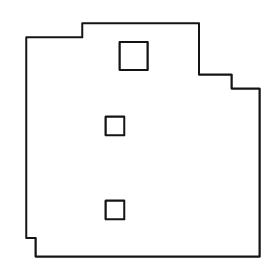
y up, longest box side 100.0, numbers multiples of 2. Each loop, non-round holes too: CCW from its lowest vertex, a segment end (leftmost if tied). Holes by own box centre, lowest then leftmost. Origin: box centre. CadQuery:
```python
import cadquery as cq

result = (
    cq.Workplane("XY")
    .moveTo(-46.0, -50.0)
    .lineTo(50.0, -50.0)
    .lineTo(50.0, 22.0)
    .lineTo(38.0, 22.0)
    .lineTo(38.0, 28.0)
    .lineTo(24.0, 28.0)
    .lineTo(24.0, 50.0)
    .lineTo(-26.0, 50.0)
    .lineTo(-26.0, 44.0)
    .lineTo(-50.0, 44.0)
    .lineTo(-50.0, -42.0)
    .lineTo(-46.0, -42.0)
    .close()
    .moveTo(-16.0, -34.0)
    .lineTo(-8.0, -34.0)
    .lineTo(-8.0, -26.0)
    .lineTo(-16.0, -26.0)
    .close()
    .moveTo(-16.0, 2.0)
    .lineTo(-8.0, 2.0)
    .lineTo(-8.0, 10.0)
    .lineTo(-16.0, 10.0)
    .close()
    .moveTo(-10.0, 30.0)
    .lineTo(2.0, 30.0)
    .lineTo(2.0, 42.0)
    .lineTo(-10.0, 42.0)
    .close()
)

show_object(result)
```